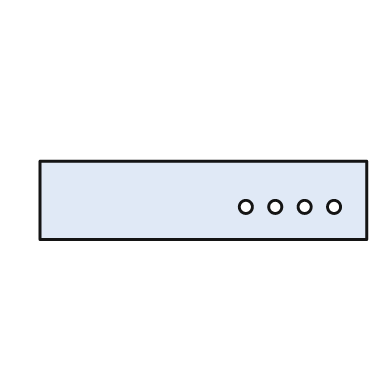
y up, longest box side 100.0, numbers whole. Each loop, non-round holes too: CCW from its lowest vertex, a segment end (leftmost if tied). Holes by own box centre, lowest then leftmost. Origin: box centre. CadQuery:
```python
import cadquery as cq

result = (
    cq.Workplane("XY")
    .moveTo(-50.0, -12.0)
    .lineTo(50.0, -12.0)
    .lineTo(50.0, 12.0)
    .lineTo(-50.0, 12.0)
    .close()
    .moveTo(13.0, -2.0)
    .circle(2.0)
    .moveTo(22.0, -2.0)
    .circle(2.0)
    .moveTo(31.0, -2.0)
    .circle(2.0)
    .moveTo(40.0, -2.0)
    .circle(2.0)
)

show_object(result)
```